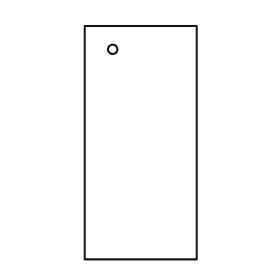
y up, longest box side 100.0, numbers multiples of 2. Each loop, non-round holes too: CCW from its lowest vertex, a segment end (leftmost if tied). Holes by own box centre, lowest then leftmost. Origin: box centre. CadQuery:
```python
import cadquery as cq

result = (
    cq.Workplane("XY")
    .moveTo(-24.0, -50.0)
    .lineTo(24.0, -50.0)
    .lineTo(24.0, 50.0)
    .lineTo(-24.0, 50.0)
    .close()
    .moveTo(-12.0, 40.0)
    .circle(2.0)
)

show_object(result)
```